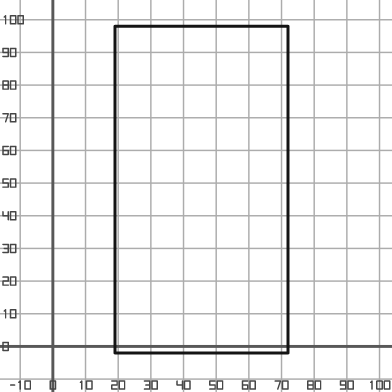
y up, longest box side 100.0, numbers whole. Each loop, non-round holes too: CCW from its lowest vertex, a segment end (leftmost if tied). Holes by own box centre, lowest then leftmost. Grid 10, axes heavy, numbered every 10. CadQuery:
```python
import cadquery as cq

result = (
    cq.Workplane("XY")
    .moveTo(19.0, -2.0)
    .lineTo(72.0, -2.0)
    .lineTo(72.0, 98.0)
    .lineTo(19.0, 98.0)
    .close()
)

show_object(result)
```